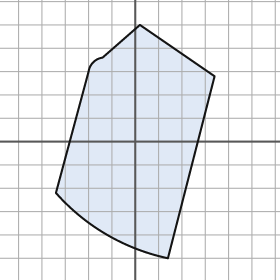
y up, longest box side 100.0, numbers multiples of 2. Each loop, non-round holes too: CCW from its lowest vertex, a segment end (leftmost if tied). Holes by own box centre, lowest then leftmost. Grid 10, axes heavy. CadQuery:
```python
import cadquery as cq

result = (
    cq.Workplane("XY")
    .moveTo(14.0, -50.0)
    .lineTo(34.0, 28.0)
    .lineTo(2.0, 50.0)
    .lineTo(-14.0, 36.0)
    .threePointArc((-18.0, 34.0), (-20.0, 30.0))
    .lineTo(-34.0, -22.0)
    .threePointArc((-12.0, -40.0), (14.0, -50.0))
    .close()
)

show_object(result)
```